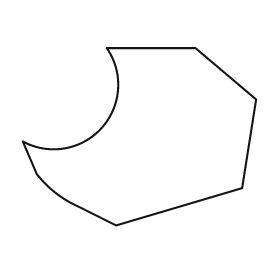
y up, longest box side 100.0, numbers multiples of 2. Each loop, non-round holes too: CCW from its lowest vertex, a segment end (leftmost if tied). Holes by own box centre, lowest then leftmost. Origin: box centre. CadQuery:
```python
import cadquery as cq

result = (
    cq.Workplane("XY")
    .moveTo(-10.0, -38.0)
    .lineTo(44.0, -22.0)
    .lineTo(50.0, 16.0)
    .lineTo(24.0, 38.0)
    .lineTo(-14.0, 38.0)
    .threePointArc((-16.0, 4.0), (-50.0, -2.0))
    .lineTo(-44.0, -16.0)
    .threePointArc((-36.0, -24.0), (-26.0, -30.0))
    .close()
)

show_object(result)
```